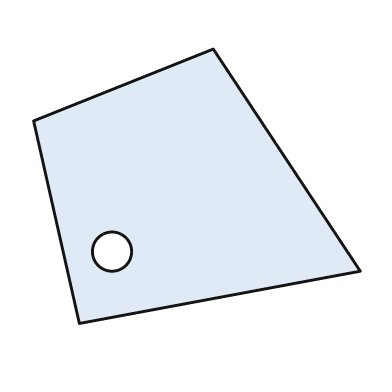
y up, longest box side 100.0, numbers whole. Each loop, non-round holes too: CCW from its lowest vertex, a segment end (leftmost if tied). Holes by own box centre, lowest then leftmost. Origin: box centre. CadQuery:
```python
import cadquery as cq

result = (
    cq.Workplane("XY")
    .moveTo(-36.0, -42.0)
    .lineTo(50.0, -26.0)
    .lineTo(5.0, 42.0)
    .lineTo(-50.0, 20.0)
    .close()
    .moveTo(-26.0, -20.0)
    .circle(6.0)
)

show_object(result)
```